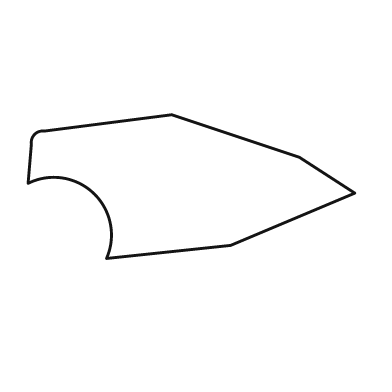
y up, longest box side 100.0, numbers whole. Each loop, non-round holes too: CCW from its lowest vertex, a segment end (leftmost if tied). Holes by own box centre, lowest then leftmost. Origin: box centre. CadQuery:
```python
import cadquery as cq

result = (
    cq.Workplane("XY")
    .moveTo(-26.0, -22.0)
    .lineTo(12.0, -18.0)
    .lineTo(50.0, -2.0)
    .lineTo(33.0, 9.0)
    .lineTo(-6.0, 22.0)
    .lineTo(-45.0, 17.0)
    .threePointArc((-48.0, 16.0), (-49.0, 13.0))
    .lineTo(-50.0, 1.0)
    .threePointArc((-30.0, -2.0), (-26.0, -22.0))
    .close()
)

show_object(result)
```